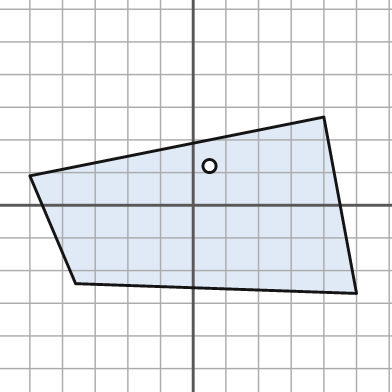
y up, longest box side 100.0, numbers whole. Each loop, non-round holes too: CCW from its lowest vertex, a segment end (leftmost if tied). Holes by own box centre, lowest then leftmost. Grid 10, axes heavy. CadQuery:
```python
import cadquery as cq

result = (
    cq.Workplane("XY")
    .moveTo(50.0, -27.0)
    .lineTo(40.0, 27.0)
    .lineTo(-50.0, 9.0)
    .lineTo(-36.0, -24.0)
    .close()
    .moveTo(5.0, 12.0)
    .circle(2.0)
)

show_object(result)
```